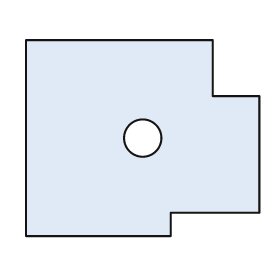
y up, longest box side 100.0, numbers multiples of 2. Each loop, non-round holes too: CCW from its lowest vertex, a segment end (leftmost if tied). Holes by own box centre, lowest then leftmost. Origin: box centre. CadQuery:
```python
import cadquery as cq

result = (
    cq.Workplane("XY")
    .moveTo(-50.0, -42.0)
    .lineTo(12.0, -42.0)
    .lineTo(12.0, -32.0)
    .lineTo(50.0, -32.0)
    .lineTo(50.0, 18.0)
    .lineTo(30.0, 18.0)
    .lineTo(30.0, 42.0)
    .lineTo(-50.0, 42.0)
    .close()
    .moveTo(0.0, 0.0)
    .circle(8.0)
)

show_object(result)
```